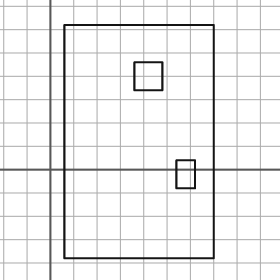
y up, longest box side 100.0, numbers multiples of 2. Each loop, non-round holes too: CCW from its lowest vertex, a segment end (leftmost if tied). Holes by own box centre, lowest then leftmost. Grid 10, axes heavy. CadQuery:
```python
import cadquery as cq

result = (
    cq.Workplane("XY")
    .moveTo(6.0, -38.0)
    .lineTo(70.0, -38.0)
    .lineTo(70.0, 62.0)
    .lineTo(6.0, 62.0)
    .close()
    .moveTo(54.0, -8.0)
    .lineTo(62.0, -8.0)
    .lineTo(62.0, 4.0)
    .lineTo(54.0, 4.0)
    .close()
    .moveTo(36.0, 34.0)
    .lineTo(48.0, 34.0)
    .lineTo(48.0, 46.0)
    .lineTo(36.0, 46.0)
    .close()
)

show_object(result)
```